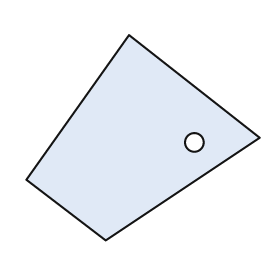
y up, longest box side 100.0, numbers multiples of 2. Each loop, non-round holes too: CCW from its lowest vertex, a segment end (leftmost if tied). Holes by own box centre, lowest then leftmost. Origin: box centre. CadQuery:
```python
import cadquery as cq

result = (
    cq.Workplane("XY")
    .moveTo(-16.0, -44.0)
    .lineTo(50.0, 0.0)
    .lineTo(-6.0, 44.0)
    .lineTo(-50.0, -18.0)
    .close()
    .moveTo(22.0, -2.0)
    .circle(4.0)
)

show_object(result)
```